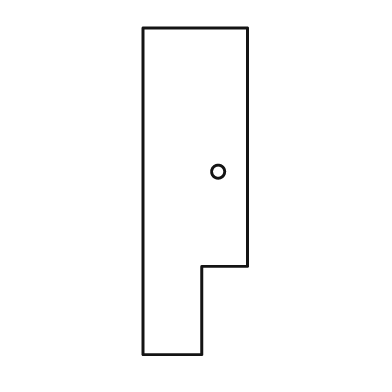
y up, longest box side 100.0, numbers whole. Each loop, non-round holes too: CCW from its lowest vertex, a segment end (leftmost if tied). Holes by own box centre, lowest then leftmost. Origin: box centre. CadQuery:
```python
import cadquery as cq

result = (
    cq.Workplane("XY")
    .moveTo(-16.0, -50.0)
    .lineTo(2.0, -50.0)
    .lineTo(2.0, -23.0)
    .lineTo(16.0, -23.0)
    .lineTo(16.0, 50.0)
    .lineTo(-16.0, 50.0)
    .close()
    .moveTo(7.0, 6.0)
    .circle(2.0)
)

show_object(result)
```